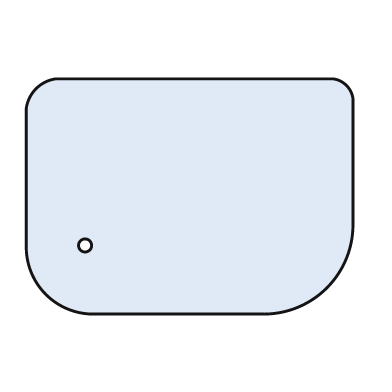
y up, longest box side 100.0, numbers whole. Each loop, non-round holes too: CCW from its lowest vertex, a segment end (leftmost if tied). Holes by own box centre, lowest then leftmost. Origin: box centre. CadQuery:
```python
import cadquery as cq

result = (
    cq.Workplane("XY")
    .moveTo(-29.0, -36.0)
    .lineTo(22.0, -36.0)
    .threePointArc((42.0, -28.0), (50.0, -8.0))
    .lineTo(50.0, 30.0)
    .threePointArc((48.0, 34.0), (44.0, 36.0))
    .lineTo(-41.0, 36.0)
    .threePointArc((-47.0, 33.0), (-50.0, 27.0))
    .lineTo(-50.0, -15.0)
    .threePointArc((-44.0, -30.0), (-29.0, -36.0))
    .close()
    .moveTo(-32.0, -15.0)
    .circle(2.0)
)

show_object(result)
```